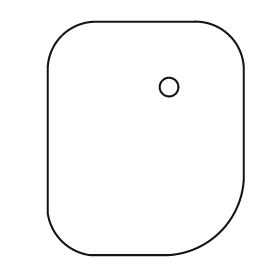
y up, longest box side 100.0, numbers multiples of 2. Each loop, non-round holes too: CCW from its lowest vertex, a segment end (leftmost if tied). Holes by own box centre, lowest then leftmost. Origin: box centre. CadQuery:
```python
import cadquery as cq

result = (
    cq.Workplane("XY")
    .moveTo(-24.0, -50.0)
    .lineTo(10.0, -50.0)
    .threePointArc((32.0, -40.0), (42.0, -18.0))
    .lineTo(42.0, 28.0)
    .threePointArc((36.0, 44.0), (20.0, 50.0))
    .lineTo(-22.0, 50.0)
    .threePointArc((-36.0, 44.0), (-42.0, 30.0))
    .lineTo(-42.0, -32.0)
    .threePointArc((-36.0, -44.0), (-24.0, -50.0))
    .close()
    .moveTo(10.0, 22.0)
    .circle(4.0)
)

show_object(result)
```